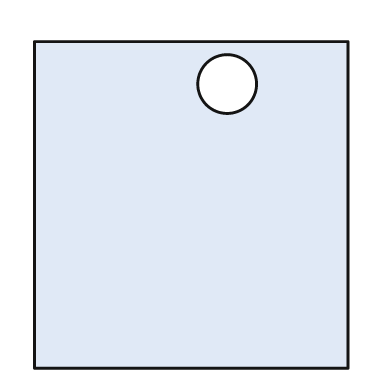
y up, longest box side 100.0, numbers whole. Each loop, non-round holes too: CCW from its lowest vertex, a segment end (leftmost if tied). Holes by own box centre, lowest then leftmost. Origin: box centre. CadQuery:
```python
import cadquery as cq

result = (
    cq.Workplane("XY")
    .moveTo(-48.0, -50.0)
    .lineTo(48.0, -50.0)
    .lineTo(48.0, 50.0)
    .lineTo(-48.0, 50.0)
    .close()
    .moveTo(11.0, 37.0)
    .circle(9.0)
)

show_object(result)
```